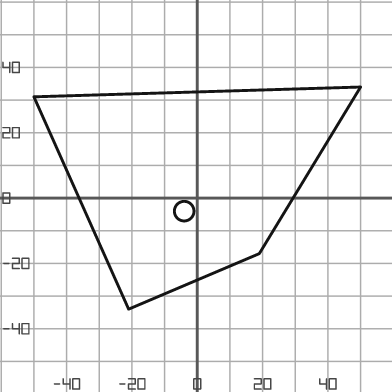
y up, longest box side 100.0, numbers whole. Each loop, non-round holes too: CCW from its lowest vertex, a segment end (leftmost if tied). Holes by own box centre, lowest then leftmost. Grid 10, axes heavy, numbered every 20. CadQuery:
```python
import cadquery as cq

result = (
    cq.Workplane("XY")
    .moveTo(-21.0, -34.0)
    .lineTo(19.0, -17.0)
    .lineTo(50.0, 34.0)
    .lineTo(-50.0, 31.0)
    .close()
    .moveTo(-4.0, -4.0)
    .circle(3.0)
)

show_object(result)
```